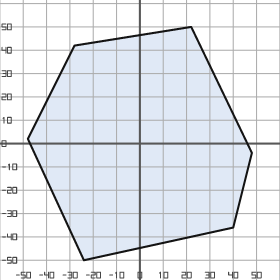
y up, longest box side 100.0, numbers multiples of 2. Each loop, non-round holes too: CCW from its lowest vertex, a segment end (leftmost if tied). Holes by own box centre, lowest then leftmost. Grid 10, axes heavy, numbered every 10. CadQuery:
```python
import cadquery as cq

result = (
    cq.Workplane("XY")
    .moveTo(-24.0, -50.0)
    .lineTo(40.0, -36.0)
    .lineTo(48.0, -4.0)
    .lineTo(22.0, 50.0)
    .lineTo(-28.0, 42.0)
    .lineTo(-48.0, 2.0)
    .close()
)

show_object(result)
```